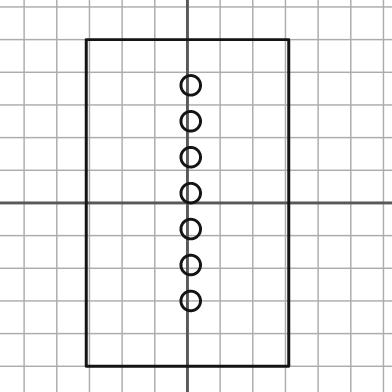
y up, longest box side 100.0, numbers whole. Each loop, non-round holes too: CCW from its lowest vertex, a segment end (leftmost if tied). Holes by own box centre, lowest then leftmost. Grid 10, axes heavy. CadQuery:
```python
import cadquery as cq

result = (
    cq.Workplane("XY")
    .moveTo(-31.0, -50.0)
    .lineTo(31.0, -50.0)
    .lineTo(31.0, 50.0)
    .lineTo(-31.0, 50.0)
    .close()
    .moveTo(1.0, -30.0)
    .circle(3.0)
    .moveTo(1.0, -19.0)
    .circle(3.0)
    .moveTo(1.0, -8.0)
    .circle(3.0)
    .moveTo(1.0, 3.0)
    .circle(3.0)
    .moveTo(1.0, 14.0)
    .circle(3.0)
    .moveTo(1.0, 25.0)
    .circle(3.0)
    .moveTo(1.0, 36.0)
    .circle(3.0)
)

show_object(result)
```